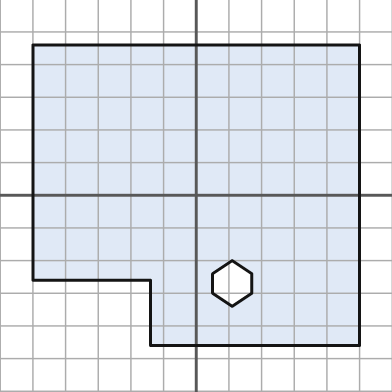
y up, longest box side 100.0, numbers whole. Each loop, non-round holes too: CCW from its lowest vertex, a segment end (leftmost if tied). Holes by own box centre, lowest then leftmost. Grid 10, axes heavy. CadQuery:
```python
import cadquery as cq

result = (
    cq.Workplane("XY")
    .moveTo(-14.0, -46.0)
    .lineTo(50.0, -46.0)
    .lineTo(50.0, 46.0)
    .lineTo(-50.0, 46.0)
    .lineTo(-50.0, -26.0)
    .lineTo(-14.0, -26.0)
    .close()
    .moveTo(11.0, -34.0)
    .lineTo(17.0, -30.0)
    .lineTo(17.0, -24.0)
    .lineTo(11.0, -20.0)
    .lineTo(5.0, -24.0)
    .lineTo(5.0, -30.0)
    .close()
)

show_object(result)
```